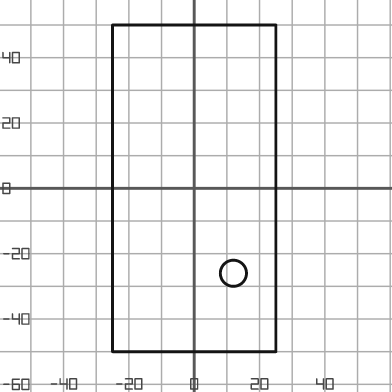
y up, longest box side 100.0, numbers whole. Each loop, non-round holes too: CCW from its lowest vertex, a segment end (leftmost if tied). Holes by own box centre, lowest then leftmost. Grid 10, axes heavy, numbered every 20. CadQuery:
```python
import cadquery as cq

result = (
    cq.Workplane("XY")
    .moveTo(-25.0, -50.0)
    .lineTo(25.0, -50.0)
    .lineTo(25.0, 50.0)
    .lineTo(-25.0, 50.0)
    .close()
    .moveTo(12.0, -26.0)
    .circle(4.0)
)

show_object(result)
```